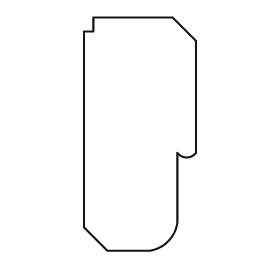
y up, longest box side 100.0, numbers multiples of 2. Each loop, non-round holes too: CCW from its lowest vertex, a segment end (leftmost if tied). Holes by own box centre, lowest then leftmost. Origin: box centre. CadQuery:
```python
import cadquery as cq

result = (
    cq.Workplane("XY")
    .moveTo(-14.0, -50.0)
    .lineTo(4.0, -50.0)
    .threePointArc((12.0, -46.0), (16.0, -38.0))
    .lineTo(16.0, -8.0)
    .threePointArc((20.0, -10.0), (24.0, -8.0))
    .lineTo(24.0, 40.0)
    .lineTo(14.0, 50.0)
    .lineTo(-20.0, 50.0)
    .lineTo(-20.0, 44.0)
    .lineTo(-24.0, 44.0)
    .lineTo(-24.0, -40.0)
    .close()
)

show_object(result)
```